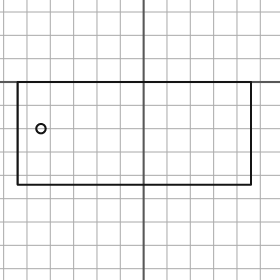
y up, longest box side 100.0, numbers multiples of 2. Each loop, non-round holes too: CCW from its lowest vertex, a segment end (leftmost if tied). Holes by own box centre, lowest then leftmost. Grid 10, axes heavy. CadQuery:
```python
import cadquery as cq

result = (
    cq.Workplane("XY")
    .moveTo(-54.0, -44.0)
    .lineTo(46.0, -44.0)
    .lineTo(46.0, 0.0)
    .lineTo(-54.0, 0.0)
    .close()
    .moveTo(-44.0, -20.0)
    .circle(2.0)
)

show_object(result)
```